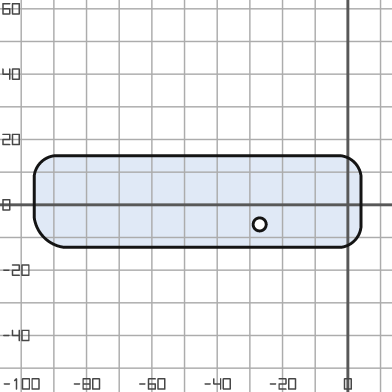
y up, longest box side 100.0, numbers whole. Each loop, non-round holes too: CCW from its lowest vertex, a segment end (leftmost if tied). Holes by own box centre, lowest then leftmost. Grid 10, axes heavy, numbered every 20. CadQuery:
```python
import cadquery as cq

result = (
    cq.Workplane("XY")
    .moveTo(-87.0, -13.0)
    .lineTo(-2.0, -13.0)
    .threePointArc((2.0, -11.0), (4.0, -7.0))
    .lineTo(4.0, 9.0)
    .threePointArc((2.0, 13.0), (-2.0, 15.0))
    .lineTo(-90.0, 15.0)
    .threePointArc((-94.0, 13.0), (-96.0, 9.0))
    .lineTo(-96.0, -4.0)
    .threePointArc((-93.0, -10.0), (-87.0, -13.0))
    .close()
    .moveTo(-27.0, -6.0)
    .circle(2.0)
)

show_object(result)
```